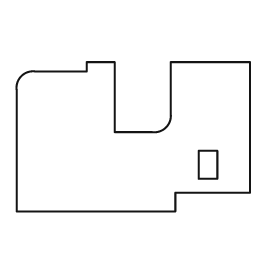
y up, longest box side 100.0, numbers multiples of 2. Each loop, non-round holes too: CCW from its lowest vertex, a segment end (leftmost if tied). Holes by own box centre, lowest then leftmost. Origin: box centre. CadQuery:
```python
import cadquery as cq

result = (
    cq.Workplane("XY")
    .moveTo(-50.0, -32.0)
    .lineTo(18.0, -32.0)
    .lineTo(18.0, -24.0)
    .lineTo(50.0, -24.0)
    .lineTo(50.0, 32.0)
    .lineTo(16.0, 32.0)
    .lineTo(16.0, 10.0)
    .threePointArc((14.0, 4.0), (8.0, 2.0))
    .lineTo(-8.0, 2.0)
    .lineTo(-8.0, 32.0)
    .lineTo(-20.0, 32.0)
    .lineTo(-20.0, 28.0)
    .lineTo(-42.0, 28.0)
    .threePointArc((-48.0, 26.0), (-50.0, 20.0))
    .close()
    .moveTo(28.0, -18.0)
    .lineTo(36.0, -18.0)
    .lineTo(36.0, -6.0)
    .lineTo(28.0, -6.0)
    .close()
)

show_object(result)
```